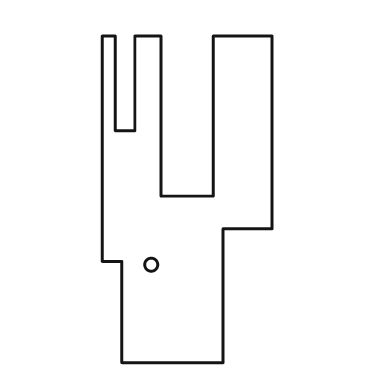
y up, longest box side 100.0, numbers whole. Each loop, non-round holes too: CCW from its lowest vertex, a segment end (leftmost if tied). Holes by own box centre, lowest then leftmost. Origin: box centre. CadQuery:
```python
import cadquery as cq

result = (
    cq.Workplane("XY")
    .moveTo(-20.0, -50.0)
    .lineTo(11.0, -50.0)
    .lineTo(11.0, -9.0)
    .lineTo(26.0, -9.0)
    .lineTo(26.0, 50.0)
    .lineTo(8.0, 50.0)
    .lineTo(8.0, 1.0)
    .lineTo(-8.0, 1.0)
    .lineTo(-8.0, 50.0)
    .lineTo(-16.0, 50.0)
    .lineTo(-16.0, 21.0)
    .lineTo(-22.0, 21.0)
    .lineTo(-22.0, 50.0)
    .lineTo(-26.0, 50.0)
    .lineTo(-26.0, -19.0)
    .lineTo(-20.0, -19.0)
    .close()
    .moveTo(-11.0, -20.0)
    .circle(2.0)
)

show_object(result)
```